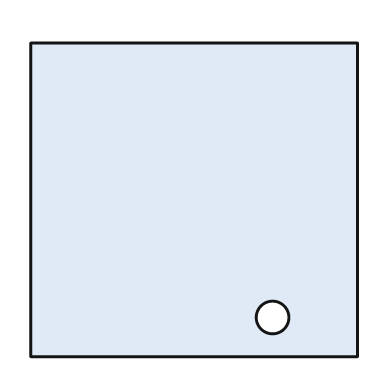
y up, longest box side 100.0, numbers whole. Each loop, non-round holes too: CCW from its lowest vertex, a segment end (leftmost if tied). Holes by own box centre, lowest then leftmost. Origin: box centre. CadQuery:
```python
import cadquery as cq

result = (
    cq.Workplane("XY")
    .moveTo(-50.0, -48.0)
    .lineTo(50.0, -48.0)
    .lineTo(50.0, 48.0)
    .lineTo(-50.0, 48.0)
    .close()
    .moveTo(24.0, -36.0)
    .circle(5.0)
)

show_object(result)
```